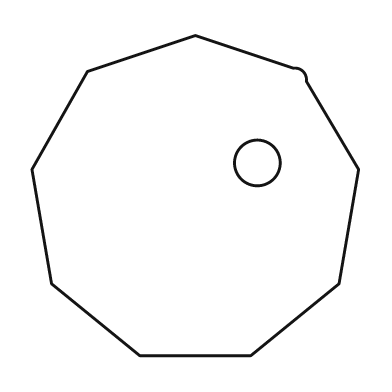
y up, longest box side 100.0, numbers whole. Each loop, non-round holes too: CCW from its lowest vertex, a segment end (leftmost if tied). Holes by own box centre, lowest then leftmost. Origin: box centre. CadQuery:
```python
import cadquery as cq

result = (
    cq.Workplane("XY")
    .moveTo(-17.0, -49.0)
    .lineTo(17.0, -49.0)
    .lineTo(44.0, -27.0)
    .lineTo(50.0, 8.0)
    .lineTo(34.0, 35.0)
    .threePointArc((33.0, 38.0), (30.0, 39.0))
    .lineTo(0.0, 49.0)
    .lineTo(-33.0, 38.0)
    .lineTo(-50.0, 8.0)
    .lineTo(-44.0, -27.0)
    .close()
    .moveTo(19.0, 10.0)
    .circle(7.0)
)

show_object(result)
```